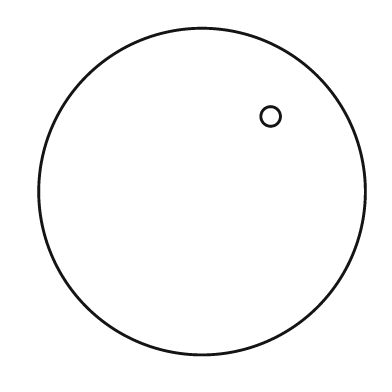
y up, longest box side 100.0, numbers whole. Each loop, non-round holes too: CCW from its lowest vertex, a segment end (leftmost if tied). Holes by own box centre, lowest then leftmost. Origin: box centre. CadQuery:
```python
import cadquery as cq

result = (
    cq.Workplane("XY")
    .moveTo(0.0, 0.0)
    .circle(50.0)
    .moveTo(21.0, 23.0)
    .circle(3.0)
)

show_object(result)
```